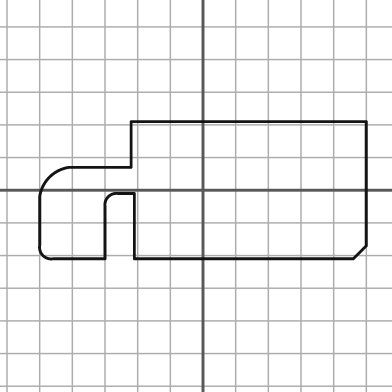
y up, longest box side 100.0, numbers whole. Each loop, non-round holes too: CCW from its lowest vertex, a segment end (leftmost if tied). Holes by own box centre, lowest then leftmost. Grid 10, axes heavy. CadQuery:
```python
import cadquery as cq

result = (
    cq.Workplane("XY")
    .moveTo(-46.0, -21.0)
    .lineTo(-30.0, -21.0)
    .lineTo(-30.0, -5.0)
    .threePointArc((-29.0, -2.0), (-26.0, -1.0))
    .lineTo(-21.0, -1.0)
    .lineTo(-21.0, -21.0)
    .lineTo(46.0, -21.0)
    .lineTo(50.0, -17.0)
    .lineTo(50.0, 21.0)
    .lineTo(-22.0, 21.0)
    .lineTo(-22.0, 7.0)
    .lineTo(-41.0, 7.0)
    .threePointArc((-47.0, 4.0), (-50.0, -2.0))
    .lineTo(-50.0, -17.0)
    .threePointArc((-49.0, -20.0), (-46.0, -21.0))
    .close()
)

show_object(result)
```